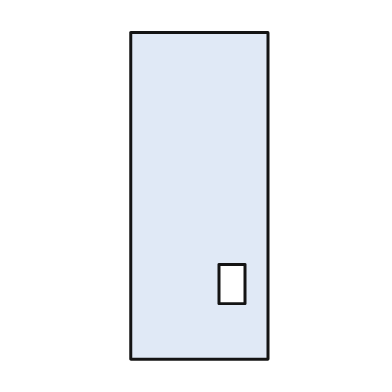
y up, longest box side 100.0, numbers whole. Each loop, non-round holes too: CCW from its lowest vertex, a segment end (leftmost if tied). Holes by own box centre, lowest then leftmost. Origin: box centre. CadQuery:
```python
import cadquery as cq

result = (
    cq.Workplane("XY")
    .moveTo(-21.0, -50.0)
    .lineTo(21.0, -50.0)
    .lineTo(21.0, 50.0)
    .lineTo(-21.0, 50.0)
    .close()
    .moveTo(6.0, -33.0)
    .lineTo(14.0, -33.0)
    .lineTo(14.0, -21.0)
    .lineTo(6.0, -21.0)
    .close()
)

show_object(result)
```